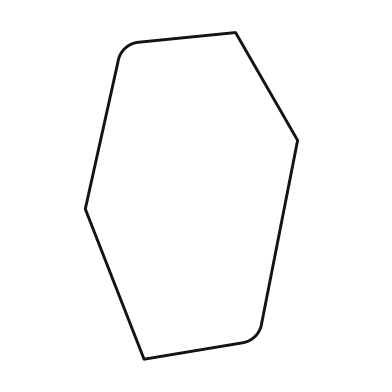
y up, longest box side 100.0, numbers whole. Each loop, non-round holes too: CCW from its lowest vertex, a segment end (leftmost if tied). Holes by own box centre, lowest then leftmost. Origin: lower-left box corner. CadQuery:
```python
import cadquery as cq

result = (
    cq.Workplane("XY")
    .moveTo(18.0, 0.0)
    .lineTo(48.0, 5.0)
    .threePointArc((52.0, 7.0), (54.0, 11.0))
    .lineTo(65.0, 67.0)
    .lineTo(46.0, 100.0)
    .lineTo(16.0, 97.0)
    .threePointArc((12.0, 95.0), (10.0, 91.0))
    .lineTo(0.0, 46.0)
    .close()
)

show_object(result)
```